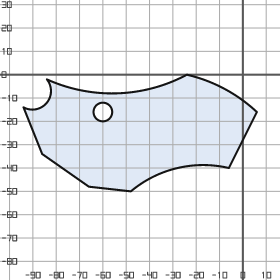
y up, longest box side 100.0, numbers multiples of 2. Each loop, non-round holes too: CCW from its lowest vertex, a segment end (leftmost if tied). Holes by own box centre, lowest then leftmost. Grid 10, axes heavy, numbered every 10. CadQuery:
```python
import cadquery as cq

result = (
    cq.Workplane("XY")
    .moveTo(-48.0, -50.0)
    .threePointArc((-28.0, -40.0), (-6.0, -40.0))
    .lineTo(6.0, -16.0)
    .threePointArc((-8.0, -6.0), (-24.0, 0.0))
    .threePointArc((-54.0, -8.0), (-84.0, -2.0))
    .threePointArc((-84.0, -12.0), (-94.0, -14.0))
    .lineTo(-86.0, -34.0)
    .lineTo(-66.0, -48.0)
    .close()
    .moveTo(-60.0, -16.0)
    .circle(4.0)
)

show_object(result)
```